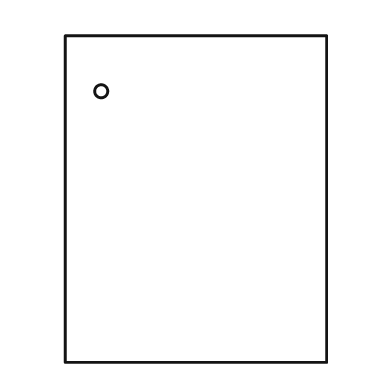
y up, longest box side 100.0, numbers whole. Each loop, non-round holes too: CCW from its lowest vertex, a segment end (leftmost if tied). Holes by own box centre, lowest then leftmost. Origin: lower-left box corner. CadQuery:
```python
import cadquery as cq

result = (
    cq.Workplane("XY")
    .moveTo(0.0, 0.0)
    .lineTo(80.0, 0.0)
    .lineTo(80.0, 100.0)
    .lineTo(0.0, 100.0)
    .close()
    .moveTo(11.0, 83.0)
    .circle(2.0)
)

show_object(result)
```